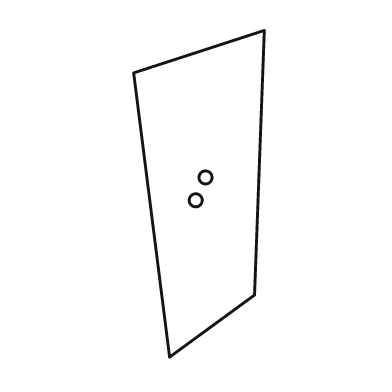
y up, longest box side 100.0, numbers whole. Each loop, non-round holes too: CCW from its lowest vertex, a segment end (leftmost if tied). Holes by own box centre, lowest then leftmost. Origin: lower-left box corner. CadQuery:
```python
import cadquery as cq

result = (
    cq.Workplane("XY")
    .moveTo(11.0, 0.0)
    .lineTo(37.0, 19.0)
    .lineTo(40.0, 100.0)
    .lineTo(0.0, 87.0)
    .close()
    .moveTo(19.0, 48.0)
    .circle(2.0)
    .moveTo(22.0, 55.0)
    .circle(2.0)
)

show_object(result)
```